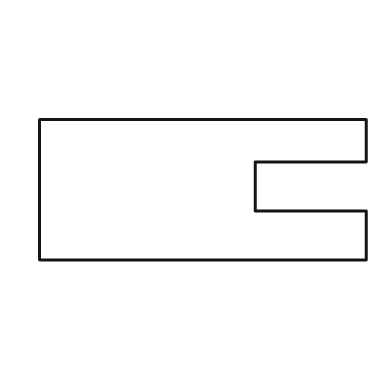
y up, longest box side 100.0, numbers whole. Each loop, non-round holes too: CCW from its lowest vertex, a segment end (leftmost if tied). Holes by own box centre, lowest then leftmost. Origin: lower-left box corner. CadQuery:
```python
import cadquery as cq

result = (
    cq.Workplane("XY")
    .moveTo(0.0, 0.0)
    .lineTo(100.0, 0.0)
    .lineTo(100.0, 15.0)
    .lineTo(66.0, 15.0)
    .lineTo(66.0, 30.0)
    .lineTo(100.0, 30.0)
    .lineTo(100.0, 43.0)
    .lineTo(0.0, 43.0)
    .close()
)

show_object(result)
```